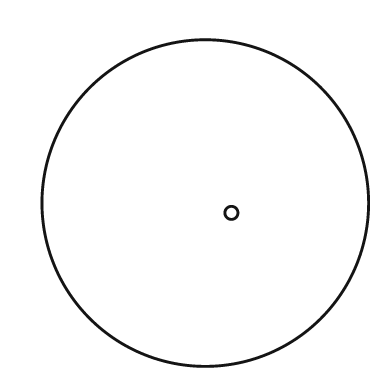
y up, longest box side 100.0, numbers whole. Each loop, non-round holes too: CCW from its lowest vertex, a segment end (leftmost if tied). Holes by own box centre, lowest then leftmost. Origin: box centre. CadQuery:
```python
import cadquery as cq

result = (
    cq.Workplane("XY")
    .moveTo(0.0, 0.0)
    .circle(50.0)
    .moveTo(8.0, -3.0)
    .circle(2.0)
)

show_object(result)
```